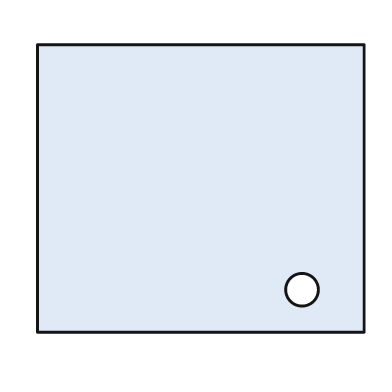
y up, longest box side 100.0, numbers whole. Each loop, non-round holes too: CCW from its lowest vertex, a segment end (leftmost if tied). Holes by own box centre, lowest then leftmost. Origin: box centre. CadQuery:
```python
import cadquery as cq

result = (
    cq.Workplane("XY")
    .moveTo(-50.0, -44.0)
    .lineTo(50.0, -44.0)
    .lineTo(50.0, 44.0)
    .lineTo(-50.0, 44.0)
    .close()
    .moveTo(31.0, -31.0)
    .circle(5.0)
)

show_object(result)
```